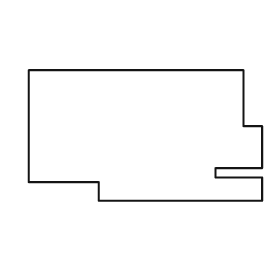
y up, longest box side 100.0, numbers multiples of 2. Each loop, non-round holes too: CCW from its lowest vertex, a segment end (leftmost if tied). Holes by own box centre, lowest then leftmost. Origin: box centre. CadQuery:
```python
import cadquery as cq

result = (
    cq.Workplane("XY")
    .moveTo(-20.0, -28.0)
    .lineTo(50.0, -28.0)
    .lineTo(50.0, -18.0)
    .lineTo(30.0, -18.0)
    .lineTo(30.0, -14.0)
    .lineTo(50.0, -14.0)
    .lineTo(50.0, 4.0)
    .lineTo(42.0, 4.0)
    .lineTo(42.0, 28.0)
    .lineTo(-50.0, 28.0)
    .lineTo(-50.0, -20.0)
    .lineTo(-20.0, -20.0)
    .close()
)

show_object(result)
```